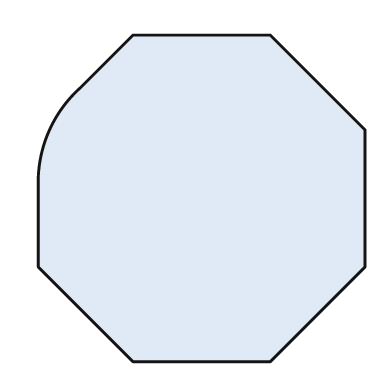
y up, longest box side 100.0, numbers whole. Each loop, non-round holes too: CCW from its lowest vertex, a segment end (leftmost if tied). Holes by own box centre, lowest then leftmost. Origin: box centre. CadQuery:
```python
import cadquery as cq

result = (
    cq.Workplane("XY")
    .moveTo(-21.0, -50.0)
    .lineTo(21.0, -50.0)
    .lineTo(50.0, -21.0)
    .lineTo(50.0, 21.0)
    .lineTo(21.0, 50.0)
    .lineTo(-21.0, 50.0)
    .lineTo(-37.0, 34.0)
    .threePointArc((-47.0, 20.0), (-50.0, 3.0))
    .lineTo(-50.0, -21.0)
    .close()
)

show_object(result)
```